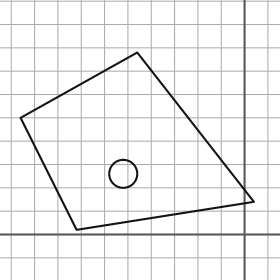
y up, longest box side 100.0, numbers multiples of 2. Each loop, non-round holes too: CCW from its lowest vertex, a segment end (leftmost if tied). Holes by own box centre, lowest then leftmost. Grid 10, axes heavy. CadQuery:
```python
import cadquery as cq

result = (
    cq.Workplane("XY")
    .moveTo(-72.0, 2.0)
    .lineTo(4.0, 14.0)
    .lineTo(-46.0, 78.0)
    .lineTo(-96.0, 50.0)
    .close()
    .moveTo(-52.0, 26.0)
    .circle(6.0)
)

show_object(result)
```